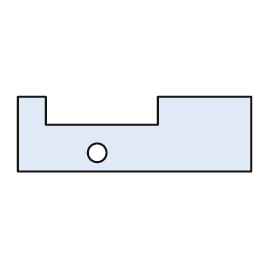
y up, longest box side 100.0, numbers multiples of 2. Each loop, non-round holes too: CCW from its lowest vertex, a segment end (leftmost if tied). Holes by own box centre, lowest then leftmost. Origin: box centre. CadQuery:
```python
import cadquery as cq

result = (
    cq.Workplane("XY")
    .moveTo(-50.0, -16.0)
    .lineTo(50.0, -16.0)
    .lineTo(50.0, 16.0)
    .lineTo(10.0, 16.0)
    .lineTo(10.0, 4.0)
    .lineTo(-38.0, 4.0)
    .lineTo(-38.0, 16.0)
    .lineTo(-50.0, 16.0)
    .close()
    .moveTo(-16.0, -8.0)
    .circle(4.0)
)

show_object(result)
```